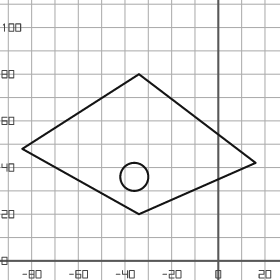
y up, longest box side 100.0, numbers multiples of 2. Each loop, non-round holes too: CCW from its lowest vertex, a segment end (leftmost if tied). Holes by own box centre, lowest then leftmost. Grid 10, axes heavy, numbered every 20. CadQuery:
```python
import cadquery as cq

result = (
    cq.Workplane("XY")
    .moveTo(-34.0, 20.0)
    .lineTo(16.0, 42.0)
    .lineTo(-34.0, 80.0)
    .lineTo(-84.0, 48.0)
    .close()
    .moveTo(-36.0, 36.0)
    .circle(6.0)
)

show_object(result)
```